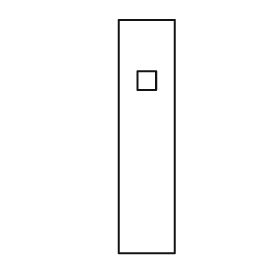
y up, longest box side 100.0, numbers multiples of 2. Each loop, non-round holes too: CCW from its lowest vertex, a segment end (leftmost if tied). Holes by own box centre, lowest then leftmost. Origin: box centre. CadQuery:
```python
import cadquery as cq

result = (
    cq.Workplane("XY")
    .moveTo(-12.0, -50.0)
    .lineTo(12.0, -50.0)
    .lineTo(12.0, 50.0)
    .lineTo(-12.0, 50.0)
    .close()
    .moveTo(-4.0, 20.0)
    .lineTo(4.0, 20.0)
    .lineTo(4.0, 28.0)
    .lineTo(-4.0, 28.0)
    .close()
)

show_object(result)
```